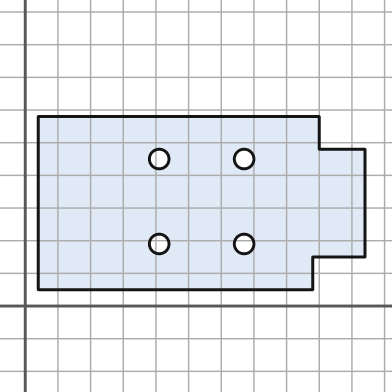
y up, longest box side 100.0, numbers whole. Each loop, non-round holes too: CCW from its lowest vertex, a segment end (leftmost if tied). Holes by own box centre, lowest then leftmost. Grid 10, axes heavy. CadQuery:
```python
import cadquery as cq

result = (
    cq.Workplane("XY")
    .moveTo(4.0, 5.0)
    .lineTo(88.0, 5.0)
    .lineTo(88.0, 15.0)
    .lineTo(104.0, 15.0)
    .lineTo(104.0, 48.0)
    .lineTo(90.0, 48.0)
    .lineTo(90.0, 58.0)
    .lineTo(4.0, 58.0)
    .close()
    .moveTo(41.0, 19.0)
    .circle(3.0)
    .moveTo(67.0, 19.0)
    .circle(3.0)
    .moveTo(41.0, 45.0)
    .circle(3.0)
    .moveTo(67.0, 45.0)
    .circle(3.0)
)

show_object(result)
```